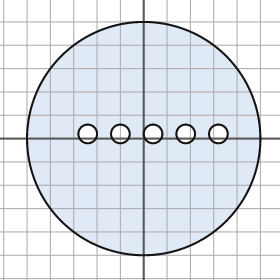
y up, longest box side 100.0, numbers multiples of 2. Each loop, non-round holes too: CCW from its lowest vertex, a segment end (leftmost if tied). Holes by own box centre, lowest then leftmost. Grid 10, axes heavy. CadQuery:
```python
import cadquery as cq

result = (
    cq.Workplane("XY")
    .moveTo(0.0, 0.0)
    .circle(50.0)
    .moveTo(-24.0, 2.0)
    .circle(4.0)
    .moveTo(-10.0, 2.0)
    .circle(4.0)
    .moveTo(4.0, 2.0)
    .circle(4.0)
    .moveTo(18.0, 2.0)
    .circle(4.0)
    .moveTo(32.0, 2.0)
    .circle(4.0)
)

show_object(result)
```